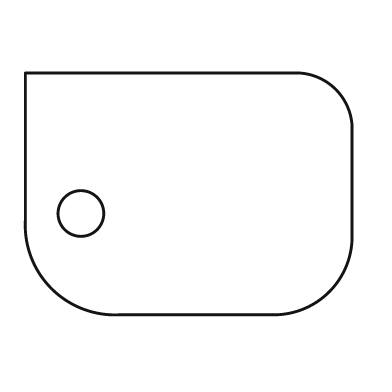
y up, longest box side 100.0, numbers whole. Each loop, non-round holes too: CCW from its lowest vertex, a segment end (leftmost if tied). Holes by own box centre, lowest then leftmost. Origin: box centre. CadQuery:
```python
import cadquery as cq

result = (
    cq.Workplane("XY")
    .moveTo(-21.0, -37.0)
    .lineTo(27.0, -37.0)
    .threePointArc((43.0, -30.0), (50.0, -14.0))
    .lineTo(50.0, 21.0)
    .threePointArc((45.0, 32.0), (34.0, 37.0))
    .lineTo(-50.0, 37.0)
    .lineTo(-50.0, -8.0)
    .threePointArc((-42.0, -29.0), (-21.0, -37.0))
    .close()
    .moveTo(-33.0, -6.0)
    .circle(7.0)
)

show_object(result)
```